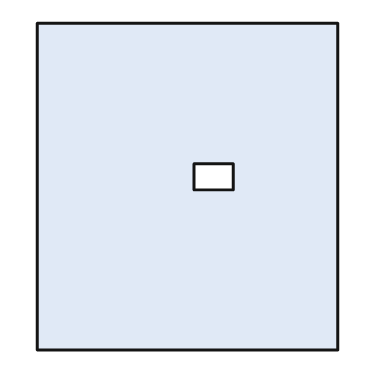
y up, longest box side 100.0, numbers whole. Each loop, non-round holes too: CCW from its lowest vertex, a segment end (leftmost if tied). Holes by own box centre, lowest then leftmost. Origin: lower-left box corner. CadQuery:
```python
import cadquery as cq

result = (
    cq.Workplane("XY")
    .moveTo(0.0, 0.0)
    .lineTo(92.0, 0.0)
    .lineTo(92.0, 100.0)
    .lineTo(0.0, 100.0)
    .close()
    .moveTo(48.0, 49.0)
    .lineTo(60.0, 49.0)
    .lineTo(60.0, 57.0)
    .lineTo(48.0, 57.0)
    .close()
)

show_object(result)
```